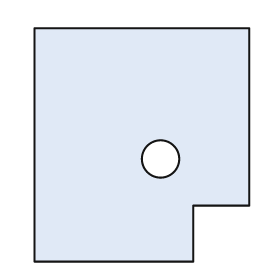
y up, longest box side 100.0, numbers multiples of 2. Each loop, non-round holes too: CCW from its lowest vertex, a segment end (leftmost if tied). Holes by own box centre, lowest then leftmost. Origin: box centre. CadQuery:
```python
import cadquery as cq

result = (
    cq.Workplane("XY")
    .moveTo(-46.0, -50.0)
    .lineTo(22.0, -50.0)
    .lineTo(22.0, -26.0)
    .lineTo(46.0, -26.0)
    .lineTo(46.0, 50.0)
    .lineTo(-46.0, 50.0)
    .close()
    .moveTo(8.0, -6.0)
    .circle(8.0)
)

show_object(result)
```